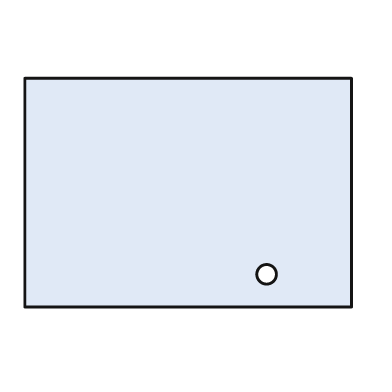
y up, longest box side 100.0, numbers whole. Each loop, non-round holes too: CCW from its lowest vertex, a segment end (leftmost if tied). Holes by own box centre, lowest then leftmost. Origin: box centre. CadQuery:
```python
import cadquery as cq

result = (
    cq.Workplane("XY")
    .moveTo(-50.0, -35.0)
    .lineTo(50.0, -35.0)
    .lineTo(50.0, 35.0)
    .lineTo(-50.0, 35.0)
    .close()
    .moveTo(24.0, -25.0)
    .circle(3.0)
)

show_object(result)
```